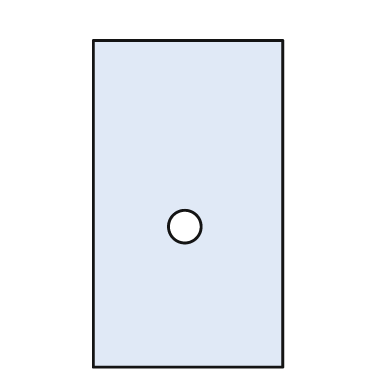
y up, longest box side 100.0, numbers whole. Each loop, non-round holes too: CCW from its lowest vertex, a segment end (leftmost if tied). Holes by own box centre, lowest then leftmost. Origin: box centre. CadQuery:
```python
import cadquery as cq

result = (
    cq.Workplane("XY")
    .moveTo(-29.0, -50.0)
    .lineTo(29.0, -50.0)
    .lineTo(29.0, 50.0)
    .lineTo(-29.0, 50.0)
    .close()
    .moveTo(-1.0, -7.0)
    .circle(5.0)
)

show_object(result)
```